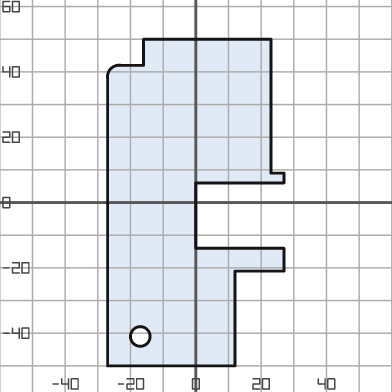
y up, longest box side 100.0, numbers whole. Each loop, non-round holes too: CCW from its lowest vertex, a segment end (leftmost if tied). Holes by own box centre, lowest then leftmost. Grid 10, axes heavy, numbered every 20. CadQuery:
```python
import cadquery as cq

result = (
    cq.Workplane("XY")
    .moveTo(-27.0, -50.0)
    .lineTo(12.0, -50.0)
    .lineTo(12.0, -21.0)
    .lineTo(27.0, -21.0)
    .lineTo(27.0, -14.0)
    .lineTo(0.0, -14.0)
    .lineTo(0.0, 6.0)
    .lineTo(27.0, 6.0)
    .lineTo(27.0, 9.0)
    .lineTo(23.0, 9.0)
    .lineTo(23.0, 50.0)
    .lineTo(-16.0, 50.0)
    .lineTo(-16.0, 42.0)
    .lineTo(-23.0, 42.0)
    .threePointArc((-26.0, 41.0), (-27.0, 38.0))
    .close()
    .moveTo(-17.0, -41.0)
    .circle(3.0)
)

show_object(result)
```